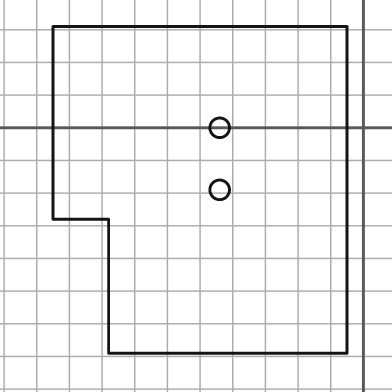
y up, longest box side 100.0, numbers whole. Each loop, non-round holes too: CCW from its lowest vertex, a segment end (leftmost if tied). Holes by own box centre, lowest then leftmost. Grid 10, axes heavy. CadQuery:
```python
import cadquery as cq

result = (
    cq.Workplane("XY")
    .moveTo(-78.0, -69.0)
    .lineTo(-5.0, -69.0)
    .lineTo(-5.0, 31.0)
    .lineTo(-95.0, 31.0)
    .lineTo(-95.0, -28.0)
    .lineTo(-78.0, -28.0)
    .close()
    .moveTo(-44.0, -19.0)
    .circle(3.0)
    .moveTo(-44.0, 0.0)
    .circle(3.0)
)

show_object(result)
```